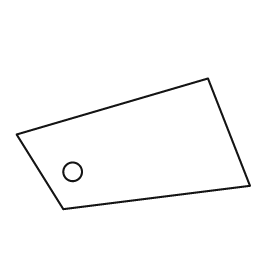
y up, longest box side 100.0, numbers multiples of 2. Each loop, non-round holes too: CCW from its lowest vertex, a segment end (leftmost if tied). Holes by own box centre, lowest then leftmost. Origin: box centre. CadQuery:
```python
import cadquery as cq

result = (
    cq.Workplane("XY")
    .moveTo(-30.0, -28.0)
    .lineTo(50.0, -18.0)
    .lineTo(32.0, 28.0)
    .lineTo(-50.0, 4.0)
    .close()
    .moveTo(-26.0, -12.0)
    .circle(4.0)
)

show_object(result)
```